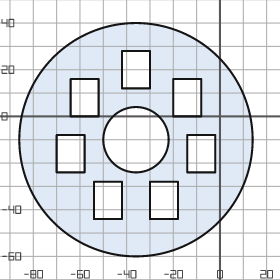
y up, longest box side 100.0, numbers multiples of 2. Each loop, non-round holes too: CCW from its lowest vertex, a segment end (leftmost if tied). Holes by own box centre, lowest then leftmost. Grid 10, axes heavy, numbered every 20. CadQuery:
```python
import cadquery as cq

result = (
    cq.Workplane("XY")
    .moveTo(-36.0, -10.0)
    .circle(50.0)
    .moveTo(-54.0, -44.0)
    .lineTo(-42.0, -44.0)
    .lineTo(-42.0, -28.0)
    .lineTo(-54.0, -28.0)
    .close()
    .moveTo(-30.0, -44.0)
    .lineTo(-18.0, -44.0)
    .lineTo(-18.0, -28.0)
    .lineTo(-30.0, -28.0)
    .close()
    .moveTo(-70.0, -24.0)
    .lineTo(-58.0, -24.0)
    .lineTo(-58.0, -8.0)
    .lineTo(-70.0, -8.0)
    .close()
    .moveTo(-14.0, -24.0)
    .lineTo(-2.0, -24.0)
    .lineTo(-2.0, -8.0)
    .lineTo(-14.0, -8.0)
    .close()
    .moveTo(-36.0, -10.0)
    .circle(14.0)
    .moveTo(-64.0, 0.0)
    .lineTo(-52.0, 0.0)
    .lineTo(-52.0, 16.0)
    .lineTo(-64.0, 16.0)
    .close()
    .moveTo(-20.0, 0.0)
    .lineTo(-8.0, 0.0)
    .lineTo(-8.0, 16.0)
    .lineTo(-20.0, 16.0)
    .close()
    .moveTo(-42.0, 12.0)
    .lineTo(-30.0, 12.0)
    .lineTo(-30.0, 28.0)
    .lineTo(-42.0, 28.0)
    .close()
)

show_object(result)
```